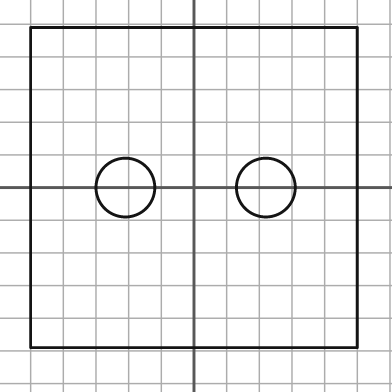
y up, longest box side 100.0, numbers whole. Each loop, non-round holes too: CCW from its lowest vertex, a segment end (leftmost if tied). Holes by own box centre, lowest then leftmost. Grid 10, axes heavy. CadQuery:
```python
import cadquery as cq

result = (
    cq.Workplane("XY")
    .moveTo(-50.0, -49.0)
    .lineTo(50.0, -49.0)
    .lineTo(50.0, 49.0)
    .lineTo(-50.0, 49.0)
    .close()
    .moveTo(-21.0, 0.0)
    .circle(9.0)
    .moveTo(22.0, 0.0)
    .circle(9.0)
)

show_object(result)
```